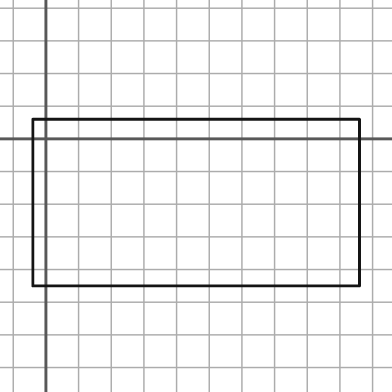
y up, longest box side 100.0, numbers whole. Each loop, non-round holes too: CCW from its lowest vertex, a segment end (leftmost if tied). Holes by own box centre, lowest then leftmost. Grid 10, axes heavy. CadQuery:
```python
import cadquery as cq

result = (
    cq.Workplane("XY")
    .moveTo(-4.0, -45.0)
    .lineTo(96.0, -45.0)
    .lineTo(96.0, 6.0)
    .lineTo(-4.0, 6.0)
    .close()
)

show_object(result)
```